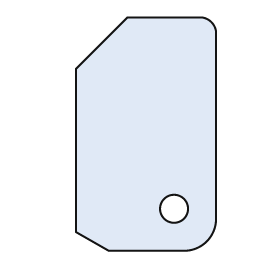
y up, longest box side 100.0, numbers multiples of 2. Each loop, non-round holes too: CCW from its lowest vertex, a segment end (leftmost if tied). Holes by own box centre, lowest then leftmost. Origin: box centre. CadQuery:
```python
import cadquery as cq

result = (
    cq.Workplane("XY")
    .moveTo(-16.0, -50.0)
    .lineTo(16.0, -50.0)
    .threePointArc((26.0, -46.0), (30.0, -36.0))
    .lineTo(30.0, 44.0)
    .threePointArc((28.0, 48.0), (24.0, 50.0))
    .lineTo(-8.0, 50.0)
    .lineTo(-30.0, 28.0)
    .lineTo(-30.0, -42.0)
    .close()
    .moveTo(12.0, -32.0)
    .circle(6.0)
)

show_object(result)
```